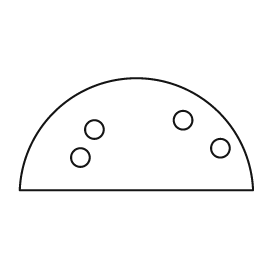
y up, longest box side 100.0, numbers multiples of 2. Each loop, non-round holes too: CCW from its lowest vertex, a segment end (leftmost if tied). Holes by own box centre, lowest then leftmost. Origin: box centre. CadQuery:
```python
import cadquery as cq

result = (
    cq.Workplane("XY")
    .moveTo(-50.0, -24.0)
    .lineTo(50.0, -24.0)
    .threePointArc((0.0, 24.0), (-50.0, -24.0))
    .close()
    .moveTo(-24.0, -10.0)
    .circle(4.0)
    .moveTo(36.0, -6.0)
    .circle(4.0)
    .moveTo(-18.0, 2.0)
    .circle(4.0)
    .moveTo(20.0, 6.0)
    .circle(4.0)
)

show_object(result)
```